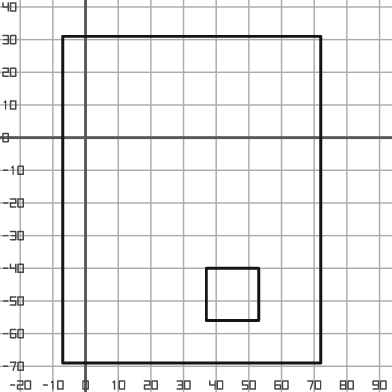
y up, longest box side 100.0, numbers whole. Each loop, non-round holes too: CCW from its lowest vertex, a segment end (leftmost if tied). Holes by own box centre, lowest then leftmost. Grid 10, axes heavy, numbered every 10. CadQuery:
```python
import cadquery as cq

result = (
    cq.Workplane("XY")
    .moveTo(-7.0, -69.0)
    .lineTo(72.0, -69.0)
    .lineTo(72.0, 31.0)
    .lineTo(-7.0, 31.0)
    .close()
    .moveTo(37.0, -56.0)
    .lineTo(53.0, -56.0)
    .lineTo(53.0, -40.0)
    .lineTo(37.0, -40.0)
    .close()
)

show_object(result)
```